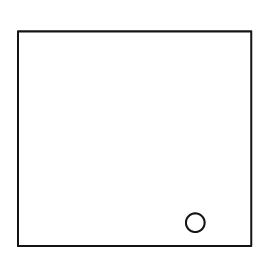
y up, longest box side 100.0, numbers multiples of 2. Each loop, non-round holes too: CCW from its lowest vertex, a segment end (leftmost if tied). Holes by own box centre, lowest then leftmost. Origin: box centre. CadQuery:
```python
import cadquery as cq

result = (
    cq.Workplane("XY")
    .moveTo(-50.0, -46.0)
    .lineTo(50.0, -46.0)
    .lineTo(50.0, 46.0)
    .lineTo(-50.0, 46.0)
    .close()
    .moveTo(26.0, -36.0)
    .circle(4.0)
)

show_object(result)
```